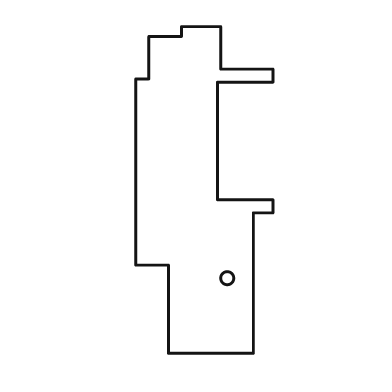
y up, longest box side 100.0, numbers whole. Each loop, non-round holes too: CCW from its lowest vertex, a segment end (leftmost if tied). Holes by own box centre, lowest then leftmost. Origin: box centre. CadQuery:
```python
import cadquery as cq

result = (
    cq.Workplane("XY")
    .moveTo(-11.0, -50.0)
    .lineTo(15.0, -50.0)
    .lineTo(15.0, -7.0)
    .lineTo(21.0, -7.0)
    .lineTo(21.0, -3.0)
    .lineTo(4.0, -3.0)
    .lineTo(4.0, 33.0)
    .lineTo(21.0, 33.0)
    .lineTo(21.0, 37.0)
    .lineTo(5.0, 37.0)
    .lineTo(5.0, 50.0)
    .lineTo(-7.0, 50.0)
    .lineTo(-7.0, 47.0)
    .lineTo(-17.0, 47.0)
    .lineTo(-17.0, 34.0)
    .lineTo(-21.0, 34.0)
    .lineTo(-21.0, -23.0)
    .lineTo(-11.0, -23.0)
    .close()
    .moveTo(7.0, -27.0)
    .circle(2.0)
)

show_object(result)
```